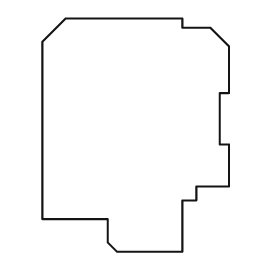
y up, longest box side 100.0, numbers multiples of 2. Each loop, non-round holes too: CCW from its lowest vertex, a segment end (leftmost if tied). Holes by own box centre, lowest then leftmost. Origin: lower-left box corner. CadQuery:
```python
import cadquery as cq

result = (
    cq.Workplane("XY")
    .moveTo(32.0, 0.0)
    .lineTo(60.0, 0.0)
    .lineTo(60.0, 22.0)
    .lineTo(66.0, 22.0)
    .lineTo(66.0, 28.0)
    .lineTo(80.0, 28.0)
    .lineTo(80.0, 46.0)
    .lineTo(76.0, 46.0)
    .lineTo(76.0, 68.0)
    .lineTo(80.0, 68.0)
    .lineTo(80.0, 88.0)
    .lineTo(72.0, 96.0)
    .lineTo(60.0, 96.0)
    .lineTo(60.0, 100.0)
    .lineTo(10.0, 100.0)
    .lineTo(0.0, 90.0)
    .lineTo(0.0, 14.0)
    .lineTo(28.0, 14.0)
    .lineTo(28.0, 4.0)
    .close()
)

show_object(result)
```